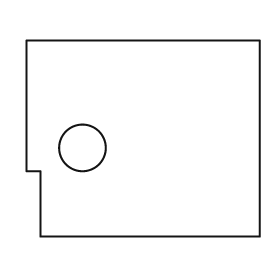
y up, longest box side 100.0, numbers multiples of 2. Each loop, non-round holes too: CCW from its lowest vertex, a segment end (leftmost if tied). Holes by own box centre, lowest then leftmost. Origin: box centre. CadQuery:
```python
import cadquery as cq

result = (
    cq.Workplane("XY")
    .moveTo(-44.0, -42.0)
    .lineTo(50.0, -42.0)
    .lineTo(50.0, 42.0)
    .lineTo(-50.0, 42.0)
    .lineTo(-50.0, -14.0)
    .lineTo(-44.0, -14.0)
    .close()
    .moveTo(-26.0, -4.0)
    .circle(10.0)
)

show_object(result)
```